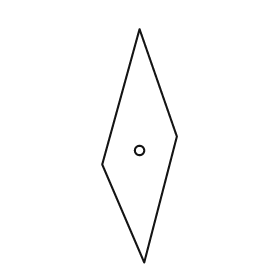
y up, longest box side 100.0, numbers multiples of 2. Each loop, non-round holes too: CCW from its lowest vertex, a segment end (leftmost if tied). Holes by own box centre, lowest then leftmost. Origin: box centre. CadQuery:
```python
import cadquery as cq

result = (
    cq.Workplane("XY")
    .moveTo(2.0, -50.0)
    .lineTo(16.0, 4.0)
    .lineTo(0.0, 50.0)
    .lineTo(-16.0, -8.0)
    .close()
    .moveTo(0.0, -2.0)
    .circle(2.0)
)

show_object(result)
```